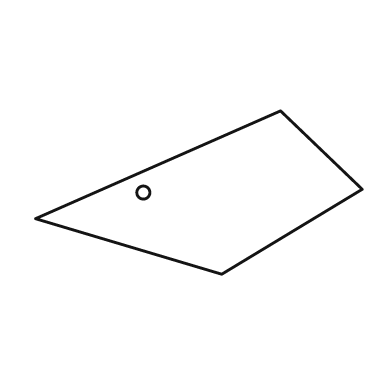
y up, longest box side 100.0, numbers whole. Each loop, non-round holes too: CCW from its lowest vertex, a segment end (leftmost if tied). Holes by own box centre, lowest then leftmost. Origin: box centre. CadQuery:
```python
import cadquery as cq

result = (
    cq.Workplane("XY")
    .moveTo(7.0, -25.0)
    .lineTo(50.0, 1.0)
    .lineTo(25.0, 25.0)
    .lineTo(-50.0, -8.0)
    .close()
    .moveTo(-17.0, 0.0)
    .circle(2.0)
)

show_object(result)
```